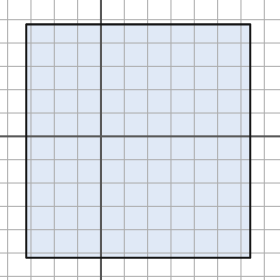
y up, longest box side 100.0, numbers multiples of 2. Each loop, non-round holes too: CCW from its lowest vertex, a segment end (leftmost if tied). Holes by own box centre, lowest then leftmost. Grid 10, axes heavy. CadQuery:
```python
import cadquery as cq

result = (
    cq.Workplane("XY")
    .moveTo(-32.0, -52.0)
    .lineTo(64.0, -52.0)
    .lineTo(64.0, 48.0)
    .lineTo(-32.0, 48.0)
    .close()
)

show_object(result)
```